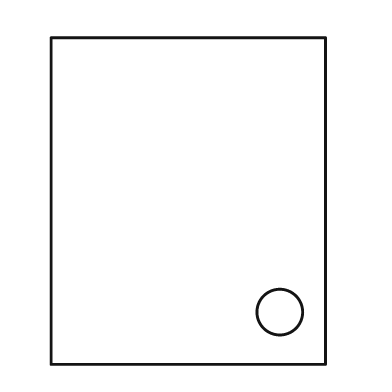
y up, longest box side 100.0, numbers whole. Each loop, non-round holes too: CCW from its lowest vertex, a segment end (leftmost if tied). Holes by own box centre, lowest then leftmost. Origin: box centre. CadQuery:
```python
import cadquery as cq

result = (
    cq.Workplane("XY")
    .moveTo(-42.0, -50.0)
    .lineTo(42.0, -50.0)
    .lineTo(42.0, 50.0)
    .lineTo(-42.0, 50.0)
    .close()
    .moveTo(28.0, -34.0)
    .circle(7.0)
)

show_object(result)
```